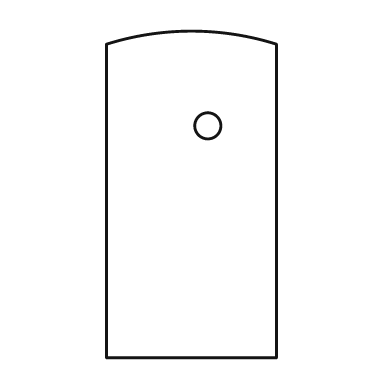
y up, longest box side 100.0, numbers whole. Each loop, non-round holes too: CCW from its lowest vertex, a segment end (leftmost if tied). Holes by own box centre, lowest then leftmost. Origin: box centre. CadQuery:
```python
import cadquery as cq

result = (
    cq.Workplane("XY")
    .moveTo(-26.0, -50.0)
    .lineTo(26.0, -50.0)
    .lineTo(26.0, 46.0)
    .threePointArc((0.0, 50.0), (-26.0, 46.0))
    .close()
    .moveTo(5.0, 21.0)
    .circle(4.0)
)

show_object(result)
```